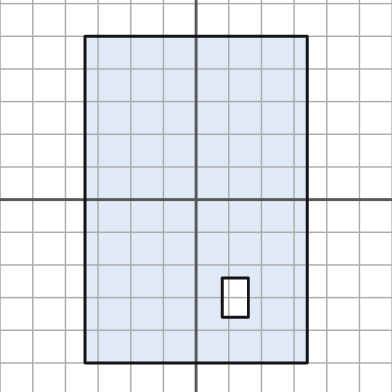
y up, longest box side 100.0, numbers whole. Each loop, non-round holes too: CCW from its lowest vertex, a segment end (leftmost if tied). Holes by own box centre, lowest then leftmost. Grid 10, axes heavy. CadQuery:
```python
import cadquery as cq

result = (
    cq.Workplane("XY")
    .moveTo(-34.0, -50.0)
    .lineTo(34.0, -50.0)
    .lineTo(34.0, 50.0)
    .lineTo(-34.0, 50.0)
    .close()
    .moveTo(8.0, -36.0)
    .lineTo(16.0, -36.0)
    .lineTo(16.0, -24.0)
    .lineTo(8.0, -24.0)
    .close()
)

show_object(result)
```